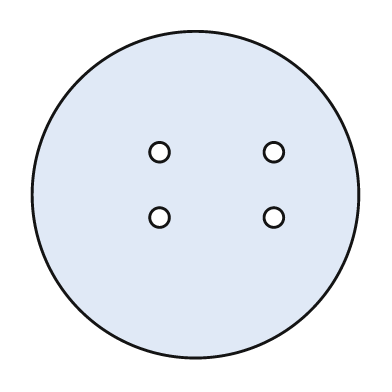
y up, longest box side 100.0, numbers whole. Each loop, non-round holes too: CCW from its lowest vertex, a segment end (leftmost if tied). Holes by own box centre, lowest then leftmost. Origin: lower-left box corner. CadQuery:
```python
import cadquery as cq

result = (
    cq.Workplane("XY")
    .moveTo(50.0, 50.0)
    .circle(50.0)
    .moveTo(39.0, 43.0)
    .circle(3.0)
    .moveTo(74.0, 43.0)
    .circle(3.0)
    .moveTo(39.0, 63.0)
    .circle(3.0)
    .moveTo(74.0, 63.0)
    .circle(3.0)
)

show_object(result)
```